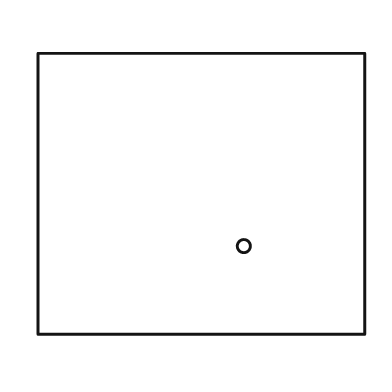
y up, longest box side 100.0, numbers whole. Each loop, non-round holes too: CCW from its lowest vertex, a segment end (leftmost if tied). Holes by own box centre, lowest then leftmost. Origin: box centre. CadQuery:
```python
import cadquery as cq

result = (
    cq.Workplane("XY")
    .moveTo(-50.0, -43.0)
    .lineTo(50.0, -43.0)
    .lineTo(50.0, 43.0)
    .lineTo(-50.0, 43.0)
    .close()
    .moveTo(13.0, -16.0)
    .circle(2.0)
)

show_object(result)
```